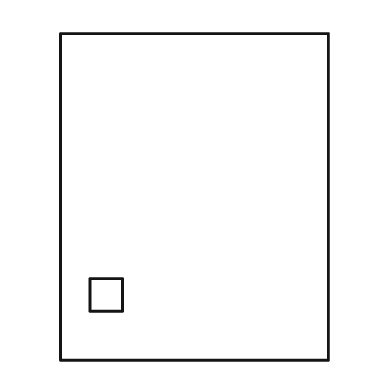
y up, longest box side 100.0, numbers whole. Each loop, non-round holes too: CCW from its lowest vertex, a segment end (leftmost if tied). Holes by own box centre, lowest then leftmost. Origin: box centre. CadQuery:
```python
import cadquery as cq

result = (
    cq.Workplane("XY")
    .moveTo(-41.0, -50.0)
    .lineTo(41.0, -50.0)
    .lineTo(41.0, 50.0)
    .lineTo(-41.0, 50.0)
    .close()
    .moveTo(-32.0, -35.0)
    .lineTo(-22.0, -35.0)
    .lineTo(-22.0, -25.0)
    .lineTo(-32.0, -25.0)
    .close()
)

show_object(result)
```